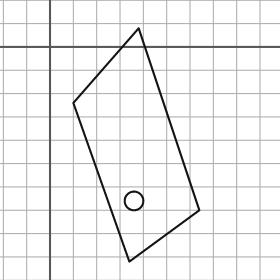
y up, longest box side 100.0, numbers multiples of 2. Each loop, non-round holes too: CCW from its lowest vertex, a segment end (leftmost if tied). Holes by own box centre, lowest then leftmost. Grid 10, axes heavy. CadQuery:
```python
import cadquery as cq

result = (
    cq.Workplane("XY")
    .moveTo(34.0, -92.0)
    .lineTo(64.0, -70.0)
    .lineTo(38.0, 8.0)
    .lineTo(10.0, -24.0)
    .close()
    .moveTo(36.0, -66.0)
    .circle(4.0)
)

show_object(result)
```